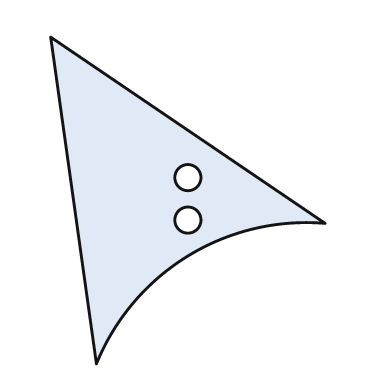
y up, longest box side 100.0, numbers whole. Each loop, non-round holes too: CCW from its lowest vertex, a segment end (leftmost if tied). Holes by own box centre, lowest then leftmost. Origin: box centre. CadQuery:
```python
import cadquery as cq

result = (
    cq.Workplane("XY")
    .moveTo(-28.0, -50.0)
    .threePointArc((0.0, -17.0), (42.0, -7.0))
    .lineTo(-42.0, 50.0)
    .close()
    .moveTo(0.0, -6.0)
    .circle(4.0)
    .moveTo(0.0, 7.0)
    .circle(4.0)
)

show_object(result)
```